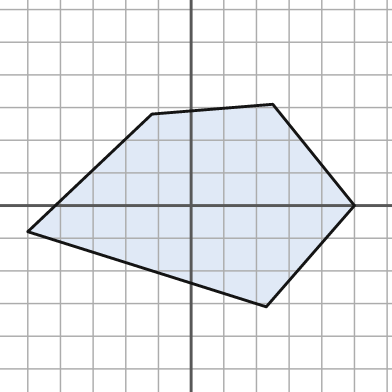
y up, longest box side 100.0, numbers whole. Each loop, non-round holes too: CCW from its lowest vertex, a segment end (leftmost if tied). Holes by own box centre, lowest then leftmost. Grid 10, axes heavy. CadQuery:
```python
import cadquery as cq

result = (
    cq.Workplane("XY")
    .moveTo(23.0, -31.0)
    .lineTo(50.0, 0.0)
    .lineTo(25.0, 31.0)
    .lineTo(-12.0, 28.0)
    .lineTo(-50.0, -8.0)
    .close()
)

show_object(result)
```